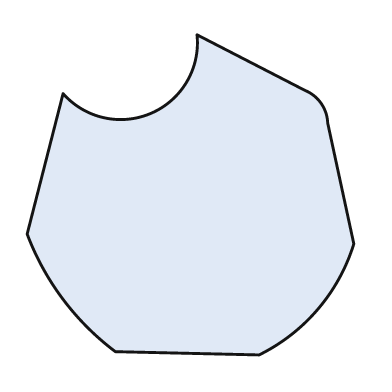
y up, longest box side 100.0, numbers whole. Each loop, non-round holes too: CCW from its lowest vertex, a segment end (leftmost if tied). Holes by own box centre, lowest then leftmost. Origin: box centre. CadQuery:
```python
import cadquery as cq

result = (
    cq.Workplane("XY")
    .moveTo(21.0, -49.0)
    .threePointArc((39.0, -35.0), (50.0, -15.0))
    .lineTo(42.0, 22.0)
    .threePointArc((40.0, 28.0), (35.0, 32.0))
    .lineTo(2.0, 49.0)
    .threePointArc((-12.0, 25.0), (-39.0, 31.0))
    .lineTo(-50.0, -12.0)
    .threePointArc((-39.0, -32.0), (-23.0, -48.0))
    .close()
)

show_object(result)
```